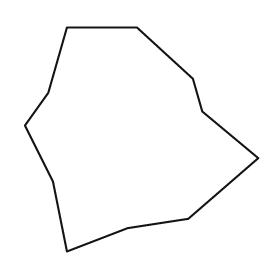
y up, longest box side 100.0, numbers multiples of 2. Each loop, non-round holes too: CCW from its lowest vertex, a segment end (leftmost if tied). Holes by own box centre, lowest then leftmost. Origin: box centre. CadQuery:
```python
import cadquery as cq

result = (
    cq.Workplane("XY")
    .moveTo(-32.0, -48.0)
    .lineTo(-6.0, -38.0)
    .lineTo(20.0, -34.0)
    .lineTo(50.0, -8.0)
    .lineTo(26.0, 12.0)
    .lineTo(22.0, 26.0)
    .lineTo(-2.0, 48.0)
    .lineTo(-32.0, 48.0)
    .lineTo(-40.0, 20.0)
    .lineTo(-50.0, 6.0)
    .lineTo(-38.0, -18.0)
    .close()
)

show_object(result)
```